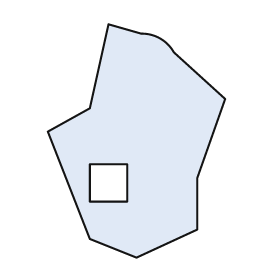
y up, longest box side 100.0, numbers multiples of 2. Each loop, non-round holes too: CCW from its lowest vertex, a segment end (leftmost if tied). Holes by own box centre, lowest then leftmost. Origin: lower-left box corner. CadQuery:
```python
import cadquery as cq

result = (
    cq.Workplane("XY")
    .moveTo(38.0, 0.0)
    .lineTo(64.0, 12.0)
    .lineTo(64.0, 34.0)
    .lineTo(76.0, 68.0)
    .lineTo(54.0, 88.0)
    .threePointArc((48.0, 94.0), (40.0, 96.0))
    .lineTo(26.0, 100.0)
    .lineTo(18.0, 64.0)
    .lineTo(0.0, 54.0)
    .lineTo(18.0, 8.0)
    .close()
    .moveTo(18.0, 24.0)
    .lineTo(34.0, 24.0)
    .lineTo(34.0, 40.0)
    .lineTo(18.0, 40.0)
    .close()
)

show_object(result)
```